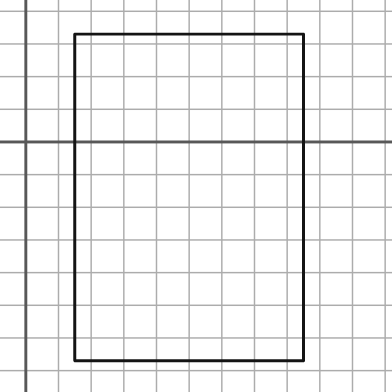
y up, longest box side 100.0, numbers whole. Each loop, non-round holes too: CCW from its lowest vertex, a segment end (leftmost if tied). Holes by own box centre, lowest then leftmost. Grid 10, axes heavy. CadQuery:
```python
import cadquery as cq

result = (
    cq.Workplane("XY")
    .moveTo(15.0, -67.0)
    .lineTo(85.0, -67.0)
    .lineTo(85.0, 33.0)
    .lineTo(15.0, 33.0)
    .close()
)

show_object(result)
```